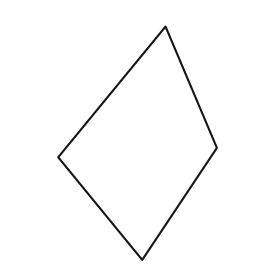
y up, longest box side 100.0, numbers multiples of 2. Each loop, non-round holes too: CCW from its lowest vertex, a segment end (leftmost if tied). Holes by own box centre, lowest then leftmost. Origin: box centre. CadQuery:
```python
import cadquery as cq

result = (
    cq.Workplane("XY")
    .moveTo(2.0, -50.0)
    .lineTo(34.0, -2.0)
    .lineTo(12.0, 50.0)
    .lineTo(-34.0, -6.0)
    .close()
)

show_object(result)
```